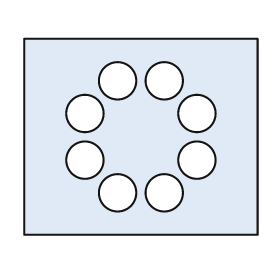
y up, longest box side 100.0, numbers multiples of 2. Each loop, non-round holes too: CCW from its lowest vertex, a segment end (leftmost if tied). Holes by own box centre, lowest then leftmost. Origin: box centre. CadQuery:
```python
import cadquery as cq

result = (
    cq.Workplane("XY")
    .moveTo(-50.0, -42.0)
    .lineTo(50.0, -42.0)
    .lineTo(50.0, 42.0)
    .lineTo(-50.0, 42.0)
    .close()
    .moveTo(-10.0, -24.0)
    .circle(8.0)
    .moveTo(10.0, -24.0)
    .circle(8.0)
    .moveTo(-24.0, -10.0)
    .circle(8.0)
    .moveTo(24.0, -10.0)
    .circle(8.0)
    .moveTo(-24.0, 10.0)
    .circle(8.0)
    .moveTo(24.0, 10.0)
    .circle(8.0)
    .moveTo(-10.0, 24.0)
    .circle(8.0)
    .moveTo(10.0, 24.0)
    .circle(8.0)
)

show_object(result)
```